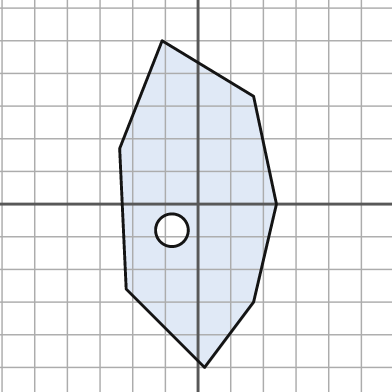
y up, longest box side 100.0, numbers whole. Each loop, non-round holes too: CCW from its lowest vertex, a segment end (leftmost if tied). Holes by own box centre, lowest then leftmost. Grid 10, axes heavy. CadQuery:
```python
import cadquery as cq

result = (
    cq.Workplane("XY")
    .moveTo(2.0, -50.0)
    .lineTo(17.0, -30.0)
    .lineTo(24.0, 0.0)
    .lineTo(17.0, 33.0)
    .lineTo(-11.0, 50.0)
    .lineTo(-24.0, 17.0)
    .lineTo(-22.0, -26.0)
    .close()
    .moveTo(-8.0, -8.0)
    .circle(5.0)
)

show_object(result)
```